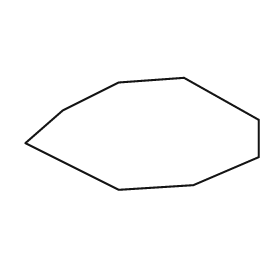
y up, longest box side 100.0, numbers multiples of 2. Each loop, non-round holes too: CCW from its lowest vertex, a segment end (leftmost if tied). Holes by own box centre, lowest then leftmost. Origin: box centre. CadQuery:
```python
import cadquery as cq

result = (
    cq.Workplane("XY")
    .moveTo(-10.0, -24.0)
    .lineTo(22.0, -22.0)
    .lineTo(50.0, -10.0)
    .lineTo(50.0, 6.0)
    .lineTo(18.0, 24.0)
    .lineTo(-10.0, 22.0)
    .lineTo(-34.0, 10.0)
    .lineTo(-50.0, -4.0)
    .close()
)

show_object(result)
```